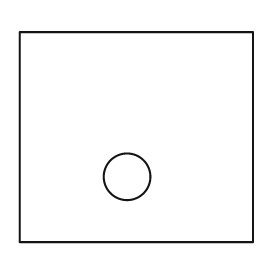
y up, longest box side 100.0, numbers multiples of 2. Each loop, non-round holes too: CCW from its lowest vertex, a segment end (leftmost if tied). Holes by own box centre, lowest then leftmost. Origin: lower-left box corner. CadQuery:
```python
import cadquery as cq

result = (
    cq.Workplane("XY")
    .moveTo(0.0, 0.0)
    .lineTo(100.0, 0.0)
    .lineTo(100.0, 90.0)
    .lineTo(0.0, 90.0)
    .close()
    .moveTo(46.0, 28.0)
    .circle(10.0)
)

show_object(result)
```